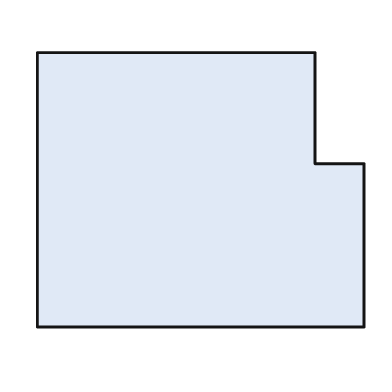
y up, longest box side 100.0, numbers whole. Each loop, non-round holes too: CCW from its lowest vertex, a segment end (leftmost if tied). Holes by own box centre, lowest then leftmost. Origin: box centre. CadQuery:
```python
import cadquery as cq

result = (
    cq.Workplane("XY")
    .moveTo(-50.0, -42.0)
    .lineTo(50.0, -42.0)
    .lineTo(50.0, 8.0)
    .lineTo(35.0, 8.0)
    .lineTo(35.0, 42.0)
    .lineTo(-50.0, 42.0)
    .close()
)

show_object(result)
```